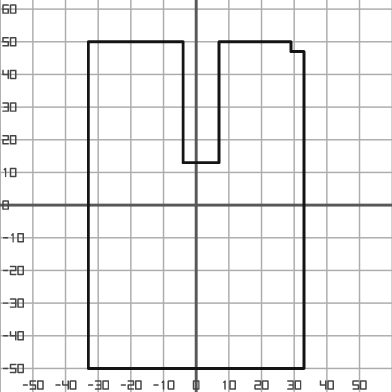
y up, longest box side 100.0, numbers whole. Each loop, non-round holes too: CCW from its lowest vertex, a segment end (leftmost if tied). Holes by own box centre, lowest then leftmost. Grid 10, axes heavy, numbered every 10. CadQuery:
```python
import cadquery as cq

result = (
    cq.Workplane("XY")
    .moveTo(-33.0, -50.0)
    .lineTo(33.0, -50.0)
    .lineTo(33.0, 47.0)
    .lineTo(29.0, 47.0)
    .lineTo(29.0, 50.0)
    .lineTo(7.0, 50.0)
    .lineTo(7.0, 13.0)
    .lineTo(-4.0, 13.0)
    .lineTo(-4.0, 50.0)
    .lineTo(-33.0, 50.0)
    .close()
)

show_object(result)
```